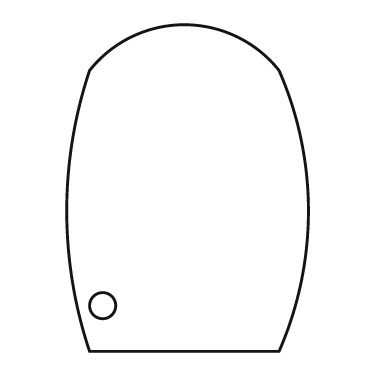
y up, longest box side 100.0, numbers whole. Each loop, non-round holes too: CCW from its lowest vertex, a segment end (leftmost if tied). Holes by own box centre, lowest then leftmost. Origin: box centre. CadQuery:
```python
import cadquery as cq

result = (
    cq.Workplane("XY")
    .moveTo(-30.0, -50.0)
    .lineTo(28.0, -50.0)
    .threePointArc((37.0, -7.0), (28.0, 36.0))
    .threePointArc((-1.0, 50.0), (-30.0, 36.0))
    .threePointArc((-37.0, -7.0), (-30.0, -50.0))
    .close()
    .moveTo(-26.0, -36.0)
    .circle(4.0)
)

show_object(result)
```